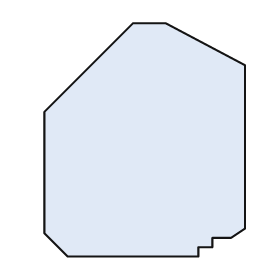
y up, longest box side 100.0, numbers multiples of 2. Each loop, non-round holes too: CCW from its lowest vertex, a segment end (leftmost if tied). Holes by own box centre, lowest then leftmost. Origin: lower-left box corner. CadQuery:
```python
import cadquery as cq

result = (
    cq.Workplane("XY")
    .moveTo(10.0, 0.0)
    .lineTo(66.0, 0.0)
    .lineTo(66.0, 4.0)
    .lineTo(72.0, 4.0)
    .lineTo(72.0, 8.0)
    .lineTo(80.0, 8.0)
    .lineTo(86.0, 12.0)
    .lineTo(86.0, 82.0)
    .lineTo(52.0, 100.0)
    .lineTo(38.0, 100.0)
    .lineTo(0.0, 62.0)
    .lineTo(0.0, 10.0)
    .close()
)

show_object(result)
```